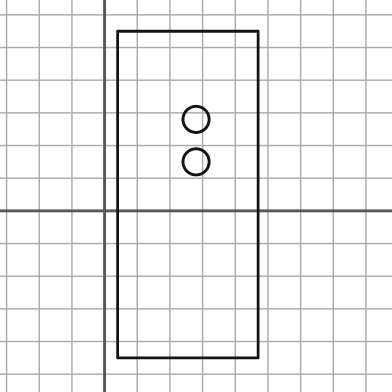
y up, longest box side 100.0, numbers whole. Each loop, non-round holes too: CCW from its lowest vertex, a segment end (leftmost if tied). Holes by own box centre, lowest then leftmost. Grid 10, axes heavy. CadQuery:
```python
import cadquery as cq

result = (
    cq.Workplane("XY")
    .moveTo(4.0, -45.0)
    .lineTo(47.0, -45.0)
    .lineTo(47.0, 55.0)
    .lineTo(4.0, 55.0)
    .close()
    .moveTo(28.0, 15.0)
    .circle(4.0)
    .moveTo(28.0, 28.0)
    .circle(4.0)
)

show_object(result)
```